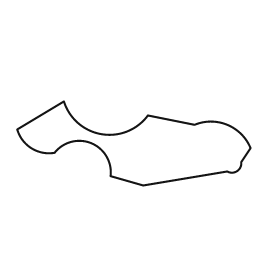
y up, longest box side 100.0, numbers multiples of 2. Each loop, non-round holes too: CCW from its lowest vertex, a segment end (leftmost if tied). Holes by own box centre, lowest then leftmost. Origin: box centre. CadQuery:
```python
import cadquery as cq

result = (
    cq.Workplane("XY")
    .moveTo(4.0, -18.0)
    .lineTo(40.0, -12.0)
    .threePointArc((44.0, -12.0), (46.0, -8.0))
    .lineTo(50.0, -2.0)
    .threePointArc((40.0, 8.0), (26.0, 8.0))
    .lineTo(6.0, 12.0)
    .threePointArc((-14.0, 4.0), (-30.0, 18.0))
    .lineTo(-50.0, 6.0)
    .threePointArc((-44.0, -2.0), (-34.0, -4.0))
    .threePointArc((-18.0, 0.0), (-10.0, -14.0))
    .close()
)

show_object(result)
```